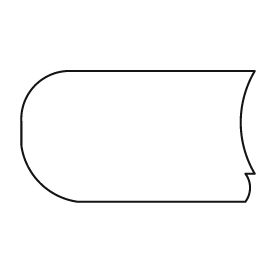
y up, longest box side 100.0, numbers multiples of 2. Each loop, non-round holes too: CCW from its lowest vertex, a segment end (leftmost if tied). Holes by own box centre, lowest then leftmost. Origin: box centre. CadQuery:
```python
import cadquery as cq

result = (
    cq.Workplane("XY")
    .moveTo(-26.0, -28.0)
    .lineTo(46.0, -28.0)
    .threePointArc((48.0, -22.0), (46.0, -16.0))
    .lineTo(50.0, -16.0)
    .threePointArc((44.0, 6.0), (50.0, 28.0))
    .lineTo(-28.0, 28.0)
    .threePointArc((-44.0, 22.0), (-50.0, 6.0))
    .lineTo(-50.0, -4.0)
    .threePointArc((-42.0, -20.0), (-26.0, -28.0))
    .close()
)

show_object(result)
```